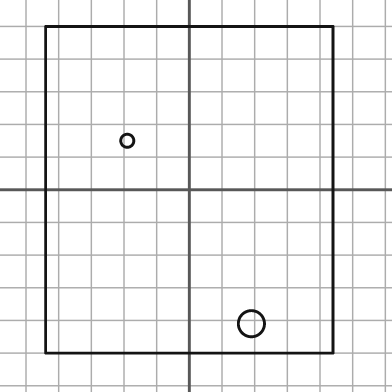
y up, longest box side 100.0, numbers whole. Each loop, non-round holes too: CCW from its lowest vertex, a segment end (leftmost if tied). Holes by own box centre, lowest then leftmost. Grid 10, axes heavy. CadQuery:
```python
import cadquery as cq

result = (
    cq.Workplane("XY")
    .moveTo(-44.0, -50.0)
    .lineTo(44.0, -50.0)
    .lineTo(44.0, 50.0)
    .lineTo(-44.0, 50.0)
    .close()
    .moveTo(19.0, -41.0)
    .circle(4.0)
    .moveTo(-19.0, 15.0)
    .circle(2.0)
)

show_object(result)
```